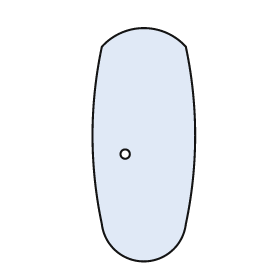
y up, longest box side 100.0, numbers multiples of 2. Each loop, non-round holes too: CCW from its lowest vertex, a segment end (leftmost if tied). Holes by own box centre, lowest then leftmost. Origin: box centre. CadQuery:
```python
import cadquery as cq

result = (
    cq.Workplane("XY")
    .moveTo(-18.0, -34.0)
    .threePointArc((0.0, -50.0), (18.0, -34.0))
    .threePointArc((22.0, 4.0), (18.0, 42.0))
    .threePointArc((0.0, 50.0), (-18.0, 42.0))
    .threePointArc((-22.0, 4.0), (-18.0, -34.0))
    .close()
    .moveTo(-8.0, -4.0)
    .circle(2.0)
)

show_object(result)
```